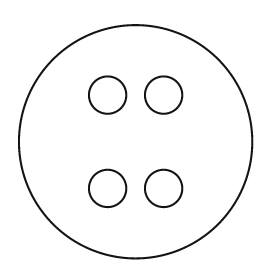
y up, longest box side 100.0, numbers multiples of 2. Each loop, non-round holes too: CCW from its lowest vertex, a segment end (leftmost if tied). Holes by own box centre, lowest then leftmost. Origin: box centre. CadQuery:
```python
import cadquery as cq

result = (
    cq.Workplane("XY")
    .moveTo(0.0, 0.0)
    .circle(50.0)
    .moveTo(-12.0, -20.0)
    .circle(8.0)
    .moveTo(12.0, -20.0)
    .circle(8.0)
    .moveTo(-12.0, 20.0)
    .circle(8.0)
    .moveTo(12.0, 20.0)
    .circle(8.0)
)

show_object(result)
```